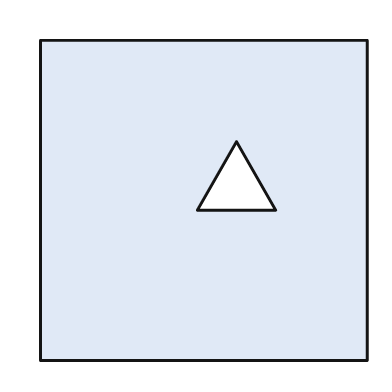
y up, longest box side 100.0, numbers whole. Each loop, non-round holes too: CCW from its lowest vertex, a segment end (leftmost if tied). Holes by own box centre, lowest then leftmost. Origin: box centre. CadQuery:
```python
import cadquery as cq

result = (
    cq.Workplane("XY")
    .moveTo(-50.0, -49.0)
    .lineTo(50.0, -49.0)
    .lineTo(50.0, 49.0)
    .lineTo(-50.0, 49.0)
    .close()
    .moveTo(-2.0, -3.0)
    .lineTo(22.0, -3.0)
    .lineTo(10.0, 18.0)
    .close()
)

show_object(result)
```